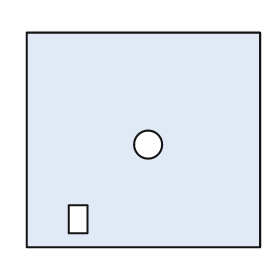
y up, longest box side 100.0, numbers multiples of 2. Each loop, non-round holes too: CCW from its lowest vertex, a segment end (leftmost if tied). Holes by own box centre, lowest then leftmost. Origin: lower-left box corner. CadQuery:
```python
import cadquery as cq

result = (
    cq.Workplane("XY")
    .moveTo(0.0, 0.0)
    .lineTo(100.0, 0.0)
    .lineTo(100.0, 92.0)
    .lineTo(0.0, 92.0)
    .close()
    .moveTo(18.0, 6.0)
    .lineTo(26.0, 6.0)
    .lineTo(26.0, 18.0)
    .lineTo(18.0, 18.0)
    .close()
    .moveTo(52.0, 44.0)
    .circle(6.0)
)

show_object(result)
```